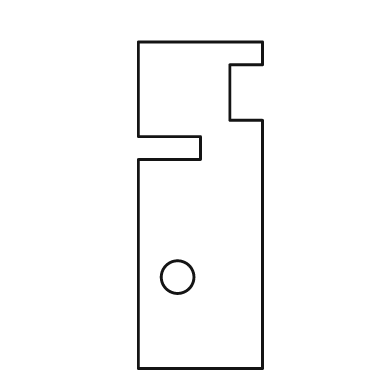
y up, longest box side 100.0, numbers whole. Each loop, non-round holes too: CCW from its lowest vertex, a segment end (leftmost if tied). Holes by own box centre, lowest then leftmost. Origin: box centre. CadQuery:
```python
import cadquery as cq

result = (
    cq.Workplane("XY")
    .moveTo(-19.0, -50.0)
    .lineTo(19.0, -50.0)
    .lineTo(19.0, 26.0)
    .lineTo(9.0, 26.0)
    .lineTo(9.0, 43.0)
    .lineTo(19.0, 43.0)
    .lineTo(19.0, 50.0)
    .lineTo(-19.0, 50.0)
    .lineTo(-19.0, 21.0)
    .lineTo(0.0, 21.0)
    .lineTo(0.0, 14.0)
    .lineTo(-19.0, 14.0)
    .close()
    .moveTo(-7.0, -22.0)
    .circle(5.0)
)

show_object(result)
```